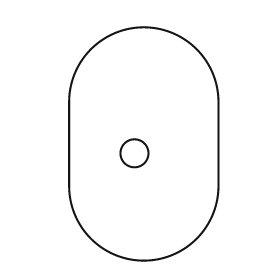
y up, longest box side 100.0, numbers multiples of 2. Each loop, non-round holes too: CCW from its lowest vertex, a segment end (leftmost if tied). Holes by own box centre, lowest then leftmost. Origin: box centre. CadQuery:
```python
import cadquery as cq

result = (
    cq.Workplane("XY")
    .moveTo(-32.0, -18.0)
    .threePointArc((0.0, -50.0), (32.0, -18.0))
    .lineTo(32.0, 18.0)
    .threePointArc((0.0, 50.0), (-32.0, 18.0))
    .close()
    .moveTo(-4.0, -4.0)
    .circle(6.0)
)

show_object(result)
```